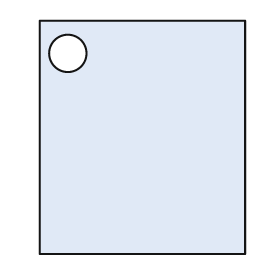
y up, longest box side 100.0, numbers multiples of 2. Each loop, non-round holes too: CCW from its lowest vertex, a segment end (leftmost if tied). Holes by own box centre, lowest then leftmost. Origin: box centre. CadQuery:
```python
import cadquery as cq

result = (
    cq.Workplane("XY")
    .moveTo(-44.0, -50.0)
    .lineTo(44.0, -50.0)
    .lineTo(44.0, 50.0)
    .lineTo(-44.0, 50.0)
    .close()
    .moveTo(-32.0, 36.0)
    .circle(8.0)
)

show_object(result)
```